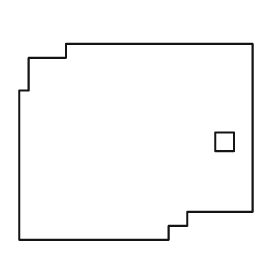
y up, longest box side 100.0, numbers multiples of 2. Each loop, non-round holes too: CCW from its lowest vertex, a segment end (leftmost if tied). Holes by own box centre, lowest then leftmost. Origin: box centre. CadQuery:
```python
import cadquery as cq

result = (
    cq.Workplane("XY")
    .moveTo(-50.0, -42.0)
    .lineTo(14.0, -42.0)
    .lineTo(14.0, -36.0)
    .lineTo(22.0, -36.0)
    .lineTo(22.0, -30.0)
    .lineTo(50.0, -30.0)
    .lineTo(50.0, 42.0)
    .lineTo(-30.0, 42.0)
    .lineTo(-30.0, 36.0)
    .lineTo(-46.0, 36.0)
    .lineTo(-46.0, 22.0)
    .lineTo(-50.0, 22.0)
    .close()
    .moveTo(34.0, -4.0)
    .lineTo(42.0, -4.0)
    .lineTo(42.0, 4.0)
    .lineTo(34.0, 4.0)
    .close()
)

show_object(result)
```